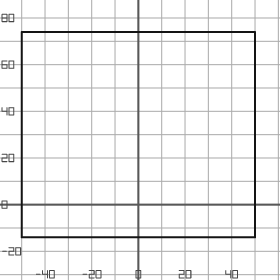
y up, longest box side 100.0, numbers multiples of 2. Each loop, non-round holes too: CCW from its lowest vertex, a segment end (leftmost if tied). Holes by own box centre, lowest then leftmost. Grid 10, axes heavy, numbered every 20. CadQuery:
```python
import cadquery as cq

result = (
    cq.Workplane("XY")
    .moveTo(-50.0, -14.0)
    .lineTo(50.0, -14.0)
    .lineTo(50.0, 74.0)
    .lineTo(-50.0, 74.0)
    .close()
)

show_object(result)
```